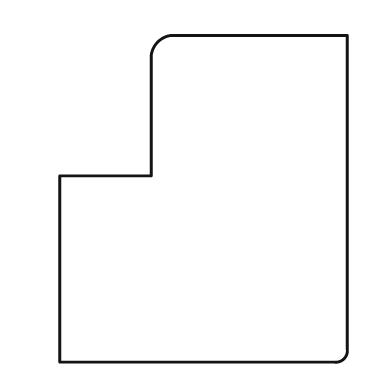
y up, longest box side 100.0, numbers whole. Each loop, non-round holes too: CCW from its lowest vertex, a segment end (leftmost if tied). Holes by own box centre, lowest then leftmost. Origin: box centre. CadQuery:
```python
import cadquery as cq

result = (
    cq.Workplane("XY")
    .moveTo(-44.0, -50.0)
    .lineTo(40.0, -50.0)
    .threePointArc((43.0, -49.0), (44.0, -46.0))
    .lineTo(44.0, 50.0)
    .lineTo(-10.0, 50.0)
    .threePointArc((-14.0, 48.0), (-16.0, 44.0))
    .lineTo(-16.0, 7.0)
    .lineTo(-44.0, 7.0)
    .close()
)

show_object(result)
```